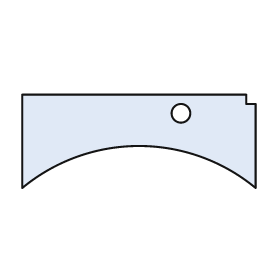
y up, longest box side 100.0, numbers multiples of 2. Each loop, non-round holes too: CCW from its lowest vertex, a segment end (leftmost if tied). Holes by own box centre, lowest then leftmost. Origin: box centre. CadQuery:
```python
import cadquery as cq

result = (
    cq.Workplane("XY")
    .moveTo(-50.0, -20.0)
    .threePointArc((0.0, -2.0), (50.0, -20.0))
    .lineTo(50.0, 16.0)
    .lineTo(46.0, 16.0)
    .lineTo(46.0, 20.0)
    .lineTo(-50.0, 20.0)
    .close()
    .moveTo(18.0, 12.0)
    .circle(4.0)
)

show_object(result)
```